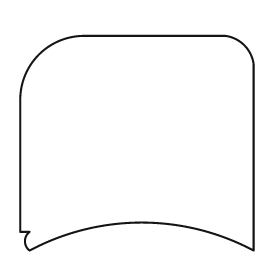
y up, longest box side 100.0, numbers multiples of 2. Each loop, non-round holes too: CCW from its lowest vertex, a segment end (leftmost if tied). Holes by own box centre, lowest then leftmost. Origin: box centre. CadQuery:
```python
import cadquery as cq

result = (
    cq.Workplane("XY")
    .moveTo(-46.0, -46.0)
    .threePointArc((2.0, -34.0), (50.0, -46.0))
    .lineTo(50.0, 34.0)
    .threePointArc((46.0, 42.0), (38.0, 46.0))
    .lineTo(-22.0, 46.0)
    .threePointArc((-42.0, 38.0), (-50.0, 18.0))
    .lineTo(-50.0, -38.0)
    .lineTo(-46.0, -38.0)
    .threePointArc((-48.0, -42.0), (-46.0, -46.0))
    .close()
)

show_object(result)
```